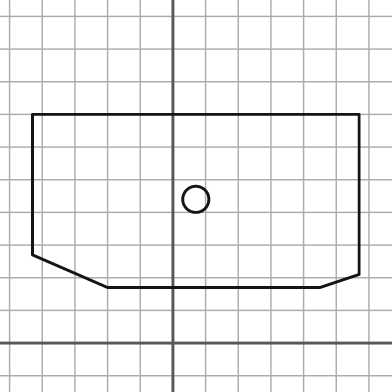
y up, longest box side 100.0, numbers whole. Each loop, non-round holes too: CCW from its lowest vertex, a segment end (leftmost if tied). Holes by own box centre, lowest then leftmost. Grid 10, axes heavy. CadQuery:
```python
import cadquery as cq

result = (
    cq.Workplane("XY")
    .moveTo(-20.0, 17.0)
    .lineTo(45.0, 17.0)
    .lineTo(57.0, 21.0)
    .lineTo(57.0, 70.0)
    .lineTo(-43.0, 70.0)
    .lineTo(-43.0, 27.0)
    .close()
    .moveTo(7.0, 44.0)
    .circle(4.0)
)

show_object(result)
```